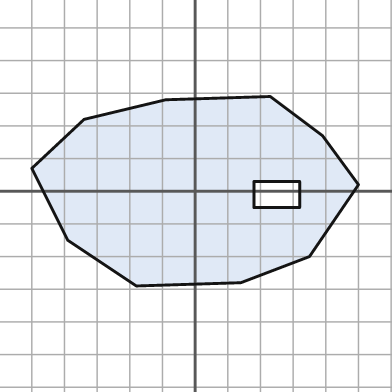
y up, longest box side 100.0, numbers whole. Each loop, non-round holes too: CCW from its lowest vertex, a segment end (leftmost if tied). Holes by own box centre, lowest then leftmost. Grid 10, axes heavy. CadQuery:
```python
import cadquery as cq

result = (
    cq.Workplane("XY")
    .moveTo(-18.0, -29.0)
    .lineTo(14.0, -28.0)
    .lineTo(35.0, -20.0)
    .lineTo(50.0, 2.0)
    .lineTo(39.0, 17.0)
    .lineTo(23.0, 29.0)
    .lineTo(-9.0, 28.0)
    .lineTo(-34.0, 22.0)
    .lineTo(-50.0, 7.0)
    .lineTo(-39.0, -15.0)
    .close()
    .moveTo(18.0, -5.0)
    .lineTo(32.0, -5.0)
    .lineTo(32.0, 3.0)
    .lineTo(18.0, 3.0)
    .close()
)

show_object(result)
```